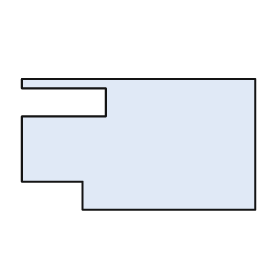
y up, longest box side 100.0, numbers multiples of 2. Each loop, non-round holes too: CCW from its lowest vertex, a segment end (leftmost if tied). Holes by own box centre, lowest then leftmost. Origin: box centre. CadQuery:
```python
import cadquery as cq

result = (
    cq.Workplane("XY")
    .moveTo(-24.0, -28.0)
    .lineTo(50.0, -28.0)
    .lineTo(50.0, 28.0)
    .lineTo(-50.0, 28.0)
    .lineTo(-50.0, 24.0)
    .lineTo(-14.0, 24.0)
    .lineTo(-14.0, 12.0)
    .lineTo(-50.0, 12.0)
    .lineTo(-50.0, -16.0)
    .lineTo(-24.0, -16.0)
    .close()
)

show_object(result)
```